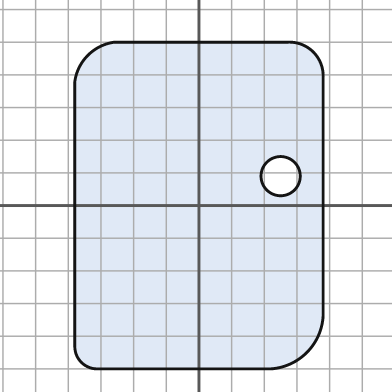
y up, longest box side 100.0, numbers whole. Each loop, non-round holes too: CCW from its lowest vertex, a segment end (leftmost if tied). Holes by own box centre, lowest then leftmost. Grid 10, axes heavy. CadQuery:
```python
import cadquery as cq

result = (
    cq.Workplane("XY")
    .moveTo(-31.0, -50.0)
    .lineTo(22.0, -50.0)
    .threePointArc((33.0, -45.0), (38.0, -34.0))
    .lineTo(38.0, 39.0)
    .threePointArc((35.0, 47.0), (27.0, 50.0))
    .lineTo(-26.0, 50.0)
    .threePointArc((-34.0, 46.0), (-38.0, 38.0))
    .lineTo(-38.0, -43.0)
    .threePointArc((-36.0, -48.0), (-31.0, -50.0))
    .close()
    .moveTo(25.0, 9.0)
    .circle(6.0)
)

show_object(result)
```